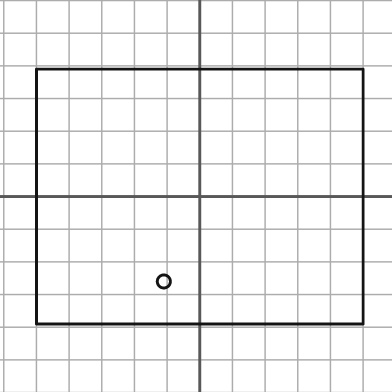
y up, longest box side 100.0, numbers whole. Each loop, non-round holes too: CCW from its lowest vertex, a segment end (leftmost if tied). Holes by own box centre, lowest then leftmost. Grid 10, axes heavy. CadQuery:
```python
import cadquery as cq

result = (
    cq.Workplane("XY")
    .moveTo(-50.0, -39.0)
    .lineTo(50.0, -39.0)
    .lineTo(50.0, 39.0)
    .lineTo(-50.0, 39.0)
    .close()
    .moveTo(-11.0, -26.0)
    .circle(2.0)
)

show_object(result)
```